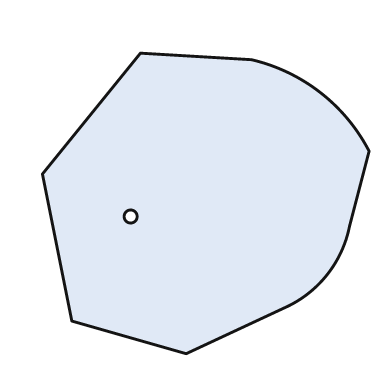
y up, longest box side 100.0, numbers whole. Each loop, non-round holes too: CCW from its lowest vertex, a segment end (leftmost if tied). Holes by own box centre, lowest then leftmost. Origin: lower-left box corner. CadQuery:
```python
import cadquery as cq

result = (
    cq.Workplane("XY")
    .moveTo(44.0, 0.0)
    .lineTo(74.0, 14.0)
    .threePointArc((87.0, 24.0), (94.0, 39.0))
    .lineTo(100.0, 62.0)
    .threePointArc((85.0, 80.0), (64.0, 90.0))
    .lineTo(30.0, 92.0)
    .lineTo(0.0, 55.0)
    .lineTo(9.0, 10.0)
    .close()
    .moveTo(27.0, 42.0)
    .circle(2.0)
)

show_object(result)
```